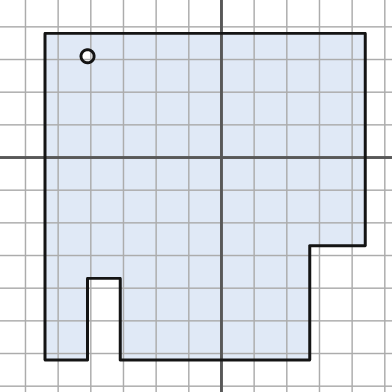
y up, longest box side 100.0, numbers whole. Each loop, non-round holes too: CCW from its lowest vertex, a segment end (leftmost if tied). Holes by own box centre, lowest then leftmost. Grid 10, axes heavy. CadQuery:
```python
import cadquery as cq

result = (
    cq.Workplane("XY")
    .moveTo(-54.0, -62.0)
    .lineTo(-41.0, -62.0)
    .lineTo(-41.0, -37.0)
    .lineTo(-31.0, -37.0)
    .lineTo(-31.0, -62.0)
    .lineTo(27.0, -62.0)
    .lineTo(27.0, -27.0)
    .lineTo(44.0, -27.0)
    .lineTo(44.0, 38.0)
    .lineTo(-54.0, 38.0)
    .close()
    .moveTo(-41.0, 31.0)
    .circle(2.0)
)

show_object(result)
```